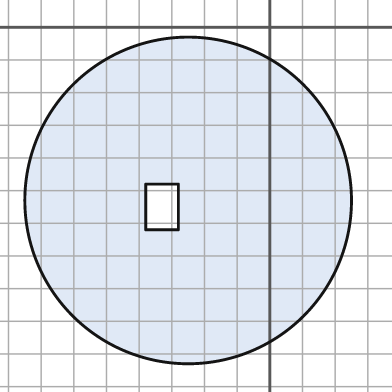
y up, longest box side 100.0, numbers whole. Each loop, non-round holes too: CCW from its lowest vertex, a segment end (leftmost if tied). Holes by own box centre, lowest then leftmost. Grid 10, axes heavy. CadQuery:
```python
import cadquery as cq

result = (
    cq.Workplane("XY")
    .moveTo(-25.0, -53.0)
    .circle(50.0)
    .moveTo(-38.0, -62.0)
    .lineTo(-28.0, -62.0)
    .lineTo(-28.0, -48.0)
    .lineTo(-38.0, -48.0)
    .close()
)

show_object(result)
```